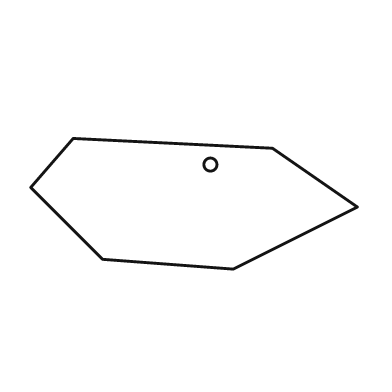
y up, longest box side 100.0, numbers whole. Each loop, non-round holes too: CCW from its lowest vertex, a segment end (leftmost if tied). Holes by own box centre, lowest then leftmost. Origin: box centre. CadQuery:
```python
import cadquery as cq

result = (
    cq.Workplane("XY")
    .moveTo(12.0, -20.0)
    .lineTo(50.0, -1.0)
    .lineTo(24.0, 17.0)
    .lineTo(-37.0, 20.0)
    .lineTo(-50.0, 5.0)
    .lineTo(-28.0, -17.0)
    .close()
    .moveTo(5.0, 12.0)
    .circle(2.0)
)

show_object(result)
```